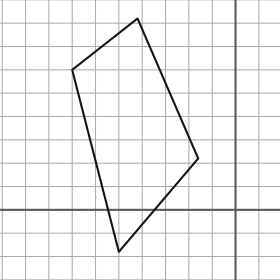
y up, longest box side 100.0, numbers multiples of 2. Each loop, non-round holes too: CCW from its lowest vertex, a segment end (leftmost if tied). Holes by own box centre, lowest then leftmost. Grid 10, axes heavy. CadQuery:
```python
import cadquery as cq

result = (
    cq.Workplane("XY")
    .moveTo(-50.0, -18.0)
    .lineTo(-16.0, 22.0)
    .lineTo(-42.0, 82.0)
    .lineTo(-70.0, 60.0)
    .close()
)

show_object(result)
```